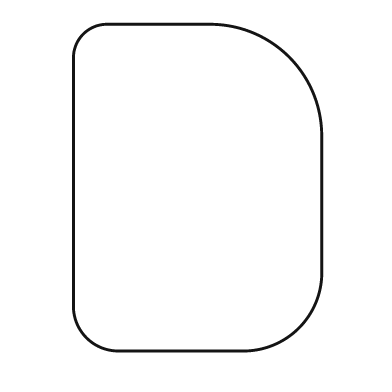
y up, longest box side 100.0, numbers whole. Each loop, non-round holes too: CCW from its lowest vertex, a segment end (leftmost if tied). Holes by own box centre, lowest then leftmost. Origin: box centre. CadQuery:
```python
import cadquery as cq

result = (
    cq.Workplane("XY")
    .moveTo(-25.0, -50.0)
    .lineTo(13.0, -50.0)
    .threePointArc((31.0, -43.0), (38.0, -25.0))
    .lineTo(38.0, 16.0)
    .threePointArc((28.0, 40.0), (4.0, 50.0))
    .lineTo(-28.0, 50.0)
    .threePointArc((-35.0, 47.0), (-38.0, 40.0))
    .lineTo(-38.0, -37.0)
    .threePointArc((-34.0, -46.0), (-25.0, -50.0))
    .close()
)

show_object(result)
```